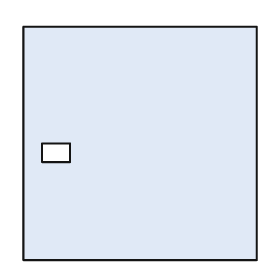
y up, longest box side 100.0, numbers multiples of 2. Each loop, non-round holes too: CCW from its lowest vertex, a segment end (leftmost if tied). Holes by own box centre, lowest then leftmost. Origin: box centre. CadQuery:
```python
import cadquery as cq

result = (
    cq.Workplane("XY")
    .moveTo(-50.0, -50.0)
    .lineTo(50.0, -50.0)
    .lineTo(50.0, 50.0)
    .lineTo(-50.0, 50.0)
    .close()
    .moveTo(-42.0, -8.0)
    .lineTo(-30.0, -8.0)
    .lineTo(-30.0, 0.0)
    .lineTo(-42.0, 0.0)
    .close()
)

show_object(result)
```